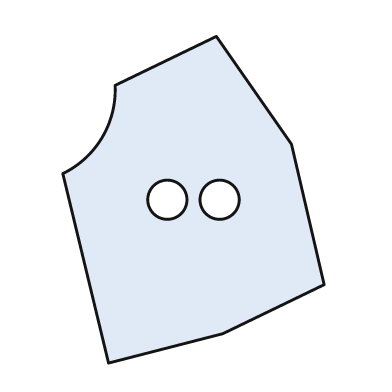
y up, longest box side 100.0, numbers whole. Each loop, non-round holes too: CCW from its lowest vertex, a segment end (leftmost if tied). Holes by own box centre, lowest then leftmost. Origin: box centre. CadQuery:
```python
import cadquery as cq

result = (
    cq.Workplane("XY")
    .moveTo(-26.0, -50.0)
    .lineTo(9.0, -41.0)
    .lineTo(40.0, -26.0)
    .lineTo(30.0, 17.0)
    .lineTo(7.0, 50.0)
    .lineTo(-24.0, 35.0)
    .threePointArc((-28.0, 19.0), (-40.0, 8.0))
    .close()
    .moveTo(-8.0, 0.0)
    .circle(6.0)
    .moveTo(8.0, 0.0)
    .circle(6.0)
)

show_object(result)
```